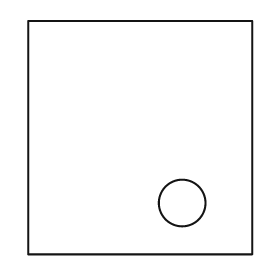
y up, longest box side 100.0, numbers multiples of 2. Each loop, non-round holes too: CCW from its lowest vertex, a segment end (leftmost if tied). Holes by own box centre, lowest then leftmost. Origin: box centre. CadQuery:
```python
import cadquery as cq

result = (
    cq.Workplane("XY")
    .moveTo(-48.0, -50.0)
    .lineTo(48.0, -50.0)
    .lineTo(48.0, 50.0)
    .lineTo(-48.0, 50.0)
    .close()
    .moveTo(18.0, -28.0)
    .circle(10.0)
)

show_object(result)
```